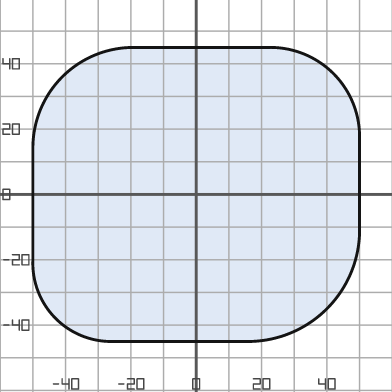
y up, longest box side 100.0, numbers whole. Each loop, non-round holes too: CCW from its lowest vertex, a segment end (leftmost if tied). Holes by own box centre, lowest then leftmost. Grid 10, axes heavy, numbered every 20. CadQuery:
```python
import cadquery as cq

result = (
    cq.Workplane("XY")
    .moveTo(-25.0, -45.0)
    .lineTo(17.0, -45.0)
    .threePointArc((40.0, -35.0), (50.0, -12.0))
    .lineTo(50.0, 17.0)
    .threePointArc((42.0, 37.0), (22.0, 45.0))
    .lineTo(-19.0, 45.0)
    .threePointArc((-41.0, 36.0), (-50.0, 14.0))
    .lineTo(-50.0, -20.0)
    .threePointArc((-43.0, -38.0), (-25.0, -45.0))
    .close()
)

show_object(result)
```